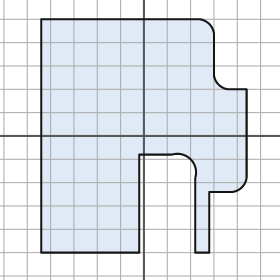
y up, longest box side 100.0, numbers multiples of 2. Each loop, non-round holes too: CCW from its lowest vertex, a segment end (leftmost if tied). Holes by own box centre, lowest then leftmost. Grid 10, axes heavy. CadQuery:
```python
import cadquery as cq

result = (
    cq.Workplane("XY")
    .moveTo(-44.0, -50.0)
    .lineTo(-2.0, -50.0)
    .lineTo(-2.0, -8.0)
    .lineTo(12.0, -8.0)
    .threePointArc((20.0, -10.0), (22.0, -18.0))
    .lineTo(22.0, -50.0)
    .lineTo(28.0, -50.0)
    .lineTo(28.0, -24.0)
    .lineTo(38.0, -24.0)
    .threePointArc((42.0, -22.0), (44.0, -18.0))
    .lineTo(44.0, 20.0)
    .lineTo(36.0, 20.0)
    .threePointArc((32.0, 22.0), (30.0, 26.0))
    .lineTo(30.0, 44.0)
    .threePointArc((28.0, 48.0), (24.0, 50.0))
    .lineTo(-44.0, 50.0)
    .close()
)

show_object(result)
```